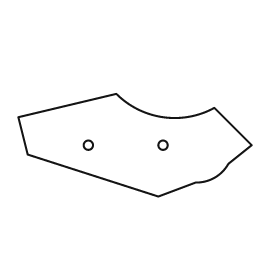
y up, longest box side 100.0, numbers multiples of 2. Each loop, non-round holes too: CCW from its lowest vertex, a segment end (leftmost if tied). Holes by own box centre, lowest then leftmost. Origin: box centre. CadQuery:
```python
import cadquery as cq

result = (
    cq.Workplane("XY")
    .moveTo(10.0, -22.0)
    .lineTo(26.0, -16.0)
    .threePointArc((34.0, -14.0), (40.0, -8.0))
    .lineTo(50.0, 0.0)
    .lineTo(34.0, 16.0)
    .threePointArc((12.0, 12.0), (-8.0, 22.0))
    .lineTo(-50.0, 12.0)
    .lineTo(-46.0, -4.0)
    .close()
    .moveTo(-20.0, 0.0)
    .circle(2.0)
    .moveTo(12.0, 0.0)
    .circle(2.0)
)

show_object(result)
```